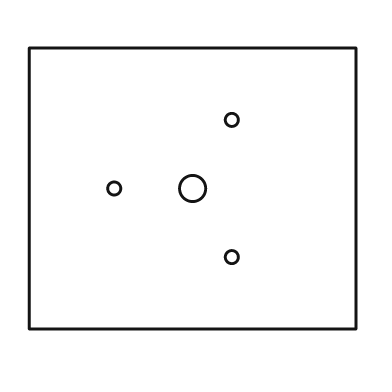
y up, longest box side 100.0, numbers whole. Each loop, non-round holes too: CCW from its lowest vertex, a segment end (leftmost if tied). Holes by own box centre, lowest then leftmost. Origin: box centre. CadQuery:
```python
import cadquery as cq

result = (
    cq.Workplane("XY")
    .moveTo(-50.0, -43.0)
    .lineTo(50.0, -43.0)
    .lineTo(50.0, 43.0)
    .lineTo(-50.0, 43.0)
    .close()
    .moveTo(12.0, -21.0)
    .circle(2.0)
    .moveTo(-24.0, 0.0)
    .circle(2.0)
    .moveTo(0.0, 0.0)
    .circle(4.0)
    .moveTo(12.0, 21.0)
    .circle(2.0)
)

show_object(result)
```